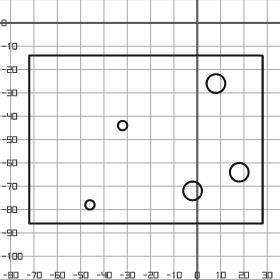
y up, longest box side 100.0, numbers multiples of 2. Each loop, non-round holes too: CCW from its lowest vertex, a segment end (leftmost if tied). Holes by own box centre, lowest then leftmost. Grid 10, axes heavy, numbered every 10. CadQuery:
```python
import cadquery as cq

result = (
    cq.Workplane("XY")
    .moveTo(-72.0, -86.0)
    .lineTo(28.0, -86.0)
    .lineTo(28.0, -14.0)
    .lineTo(-72.0, -14.0)
    .close()
    .moveTo(-46.0, -78.0)
    .circle(2.0)
    .moveTo(-2.0, -72.0)
    .circle(4.0)
    .moveTo(18.0, -64.0)
    .circle(4.0)
    .moveTo(-32.0, -44.0)
    .circle(2.0)
    .moveTo(8.0, -26.0)
    .circle(4.0)
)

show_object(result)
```